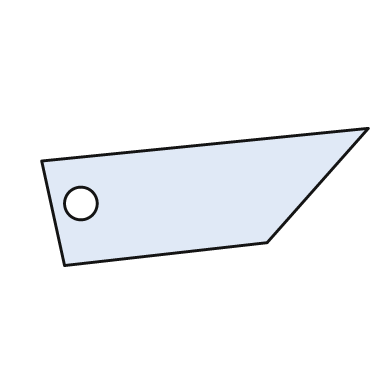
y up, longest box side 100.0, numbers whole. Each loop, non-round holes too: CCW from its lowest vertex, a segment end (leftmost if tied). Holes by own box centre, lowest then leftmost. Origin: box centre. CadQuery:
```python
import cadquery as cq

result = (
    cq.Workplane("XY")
    .moveTo(-43.0, -21.0)
    .lineTo(19.0, -14.0)
    .lineTo(50.0, 21.0)
    .lineTo(-50.0, 11.0)
    .close()
    .moveTo(-38.0, -2.0)
    .circle(5.0)
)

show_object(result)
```